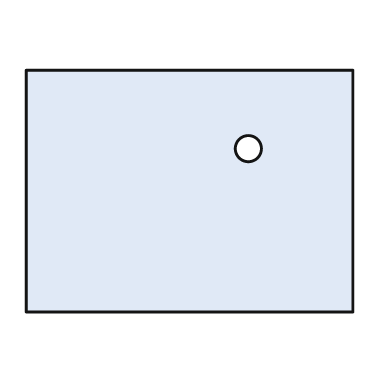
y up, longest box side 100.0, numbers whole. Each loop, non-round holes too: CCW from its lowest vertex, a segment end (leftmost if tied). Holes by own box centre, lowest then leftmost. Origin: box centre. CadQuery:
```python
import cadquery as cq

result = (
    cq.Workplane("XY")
    .moveTo(-50.0, -37.0)
    .lineTo(50.0, -37.0)
    .lineTo(50.0, 37.0)
    .lineTo(-50.0, 37.0)
    .close()
    .moveTo(18.0, 13.0)
    .circle(4.0)
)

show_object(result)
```